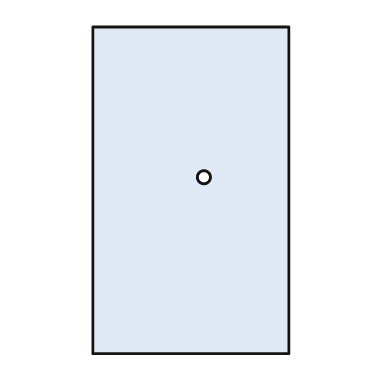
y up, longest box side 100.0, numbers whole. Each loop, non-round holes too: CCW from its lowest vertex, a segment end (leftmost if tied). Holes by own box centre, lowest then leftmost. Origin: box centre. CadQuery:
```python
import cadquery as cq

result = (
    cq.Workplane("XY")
    .moveTo(-30.0, -50.0)
    .lineTo(30.0, -50.0)
    .lineTo(30.0, 50.0)
    .lineTo(-30.0, 50.0)
    .close()
    .moveTo(4.0, 4.0)
    .circle(2.0)
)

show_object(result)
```